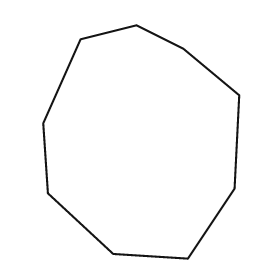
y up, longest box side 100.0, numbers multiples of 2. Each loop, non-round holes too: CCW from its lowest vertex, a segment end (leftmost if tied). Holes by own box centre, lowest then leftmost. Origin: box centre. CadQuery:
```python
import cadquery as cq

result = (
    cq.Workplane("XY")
    .moveTo(20.0, -50.0)
    .lineTo(40.0, -20.0)
    .lineTo(42.0, 20.0)
    .lineTo(18.0, 40.0)
    .lineTo(-2.0, 50.0)
    .lineTo(-26.0, 44.0)
    .lineTo(-42.0, 8.0)
    .lineTo(-40.0, -22.0)
    .lineTo(-12.0, -48.0)
    .close()
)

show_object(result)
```